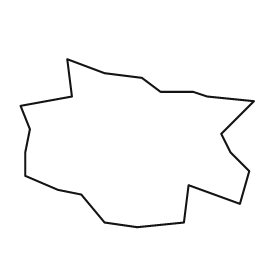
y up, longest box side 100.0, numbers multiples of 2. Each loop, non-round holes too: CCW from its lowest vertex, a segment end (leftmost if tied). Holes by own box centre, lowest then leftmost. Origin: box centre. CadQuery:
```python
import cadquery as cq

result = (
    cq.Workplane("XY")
    .moveTo(0.0, -36.0)
    .lineTo(20.0, -34.0)
    .lineTo(22.0, -18.0)
    .lineTo(44.0, -26.0)
    .lineTo(48.0, -12.0)
    .lineTo(40.0, -4.0)
    .lineTo(36.0, 4.0)
    .lineTo(50.0, 18.0)
    .lineTo(30.0, 20.0)
    .lineTo(24.0, 22.0)
    .lineTo(10.0, 22.0)
    .lineTo(2.0, 28.0)
    .lineTo(-14.0, 30.0)
    .lineTo(-30.0, 36.0)
    .lineTo(-28.0, 20.0)
    .lineTo(-50.0, 16.0)
    .lineTo(-46.0, 6.0)
    .lineTo(-48.0, -4.0)
    .lineTo(-48.0, -14.0)
    .lineTo(-34.0, -20.0)
    .lineTo(-24.0, -22.0)
    .lineTo(-14.0, -34.0)
    .close()
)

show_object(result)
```